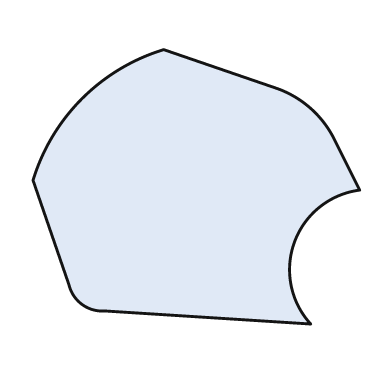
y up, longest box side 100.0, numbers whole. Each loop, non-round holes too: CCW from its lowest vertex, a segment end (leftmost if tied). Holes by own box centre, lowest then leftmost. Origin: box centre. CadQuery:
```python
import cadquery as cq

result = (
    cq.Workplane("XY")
    .moveTo(35.0, -42.0)
    .threePointArc((30.0, -17.0), (50.0, -1.0))
    .lineTo(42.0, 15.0)
    .threePointArc((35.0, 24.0), (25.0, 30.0))
    .lineTo(-10.0, 42.0)
    .threePointArc((-35.0, 27.0), (-50.0, 2.0))
    .lineTo(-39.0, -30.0)
    .threePointArc((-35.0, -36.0), (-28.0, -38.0))
    .close()
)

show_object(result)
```